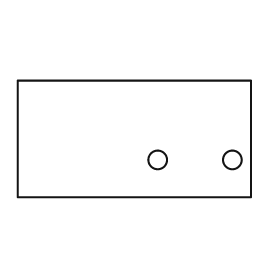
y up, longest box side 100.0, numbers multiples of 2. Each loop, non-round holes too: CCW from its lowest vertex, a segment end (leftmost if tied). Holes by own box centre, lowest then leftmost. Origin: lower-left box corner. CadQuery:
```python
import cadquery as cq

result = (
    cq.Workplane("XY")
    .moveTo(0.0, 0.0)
    .lineTo(100.0, 0.0)
    .lineTo(100.0, 50.0)
    .lineTo(0.0, 50.0)
    .close()
    .moveTo(60.0, 16.0)
    .circle(4.0)
    .moveTo(92.0, 16.0)
    .circle(4.0)
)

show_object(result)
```